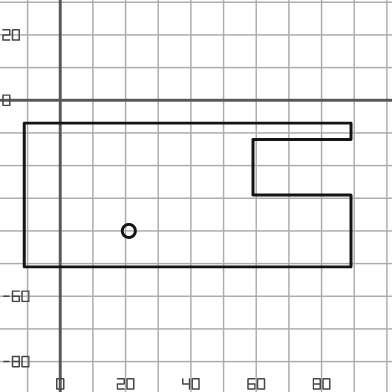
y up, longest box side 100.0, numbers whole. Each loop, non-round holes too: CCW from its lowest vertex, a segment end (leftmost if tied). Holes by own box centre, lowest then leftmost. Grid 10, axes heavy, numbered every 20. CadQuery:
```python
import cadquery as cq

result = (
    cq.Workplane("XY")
    .moveTo(-11.0, -51.0)
    .lineTo(89.0, -51.0)
    .lineTo(89.0, -29.0)
    .lineTo(59.0, -29.0)
    .lineTo(59.0, -12.0)
    .lineTo(89.0, -12.0)
    .lineTo(89.0, -7.0)
    .lineTo(-11.0, -7.0)
    .close()
    .moveTo(21.0, -40.0)
    .circle(2.0)
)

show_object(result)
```